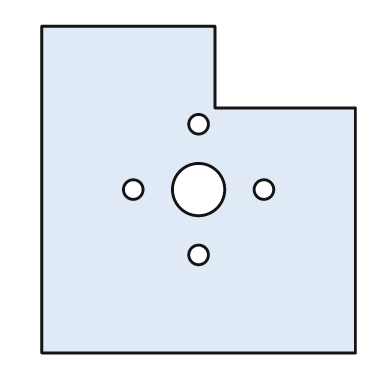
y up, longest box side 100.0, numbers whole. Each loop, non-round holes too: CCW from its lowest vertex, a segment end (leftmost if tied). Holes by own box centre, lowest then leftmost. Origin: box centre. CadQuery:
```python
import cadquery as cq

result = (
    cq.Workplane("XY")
    .moveTo(-48.0, -50.0)
    .lineTo(48.0, -50.0)
    .lineTo(48.0, 25.0)
    .lineTo(5.0, 25.0)
    .lineTo(5.0, 50.0)
    .lineTo(-48.0, 50.0)
    .close()
    .moveTo(0.0, -20.0)
    .circle(3.0)
    .moveTo(-20.0, 0.0)
    .circle(3.0)
    .moveTo(0.0, 0.0)
    .circle(8.0)
    .moveTo(20.0, 0.0)
    .circle(3.0)
    .moveTo(0.0, 20.0)
    .circle(3.0)
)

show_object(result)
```